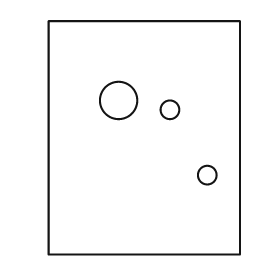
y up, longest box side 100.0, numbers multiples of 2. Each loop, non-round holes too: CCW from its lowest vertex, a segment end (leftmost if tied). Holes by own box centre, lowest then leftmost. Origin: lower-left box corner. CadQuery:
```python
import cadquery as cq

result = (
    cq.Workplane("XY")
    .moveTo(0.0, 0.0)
    .lineTo(82.0, 0.0)
    .lineTo(82.0, 100.0)
    .lineTo(0.0, 100.0)
    .close()
    .moveTo(68.0, 34.0)
    .circle(4.0)
    .moveTo(52.0, 62.0)
    .circle(4.0)
    .moveTo(30.0, 66.0)
    .circle(8.0)
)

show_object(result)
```